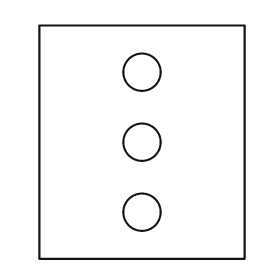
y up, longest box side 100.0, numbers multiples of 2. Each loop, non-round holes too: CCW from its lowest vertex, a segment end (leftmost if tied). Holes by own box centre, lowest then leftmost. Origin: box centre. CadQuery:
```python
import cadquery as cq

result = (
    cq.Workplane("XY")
    .moveTo(-44.0, -50.0)
    .lineTo(44.0, -50.0)
    .lineTo(44.0, 50.0)
    .lineTo(-44.0, 50.0)
    .close()
    .moveTo(0.0, -30.0)
    .circle(8.0)
    .moveTo(0.0, 0.0)
    .circle(8.0)
    .moveTo(0.0, 30.0)
    .circle(8.0)
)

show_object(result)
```